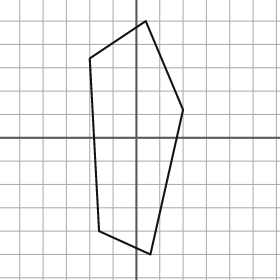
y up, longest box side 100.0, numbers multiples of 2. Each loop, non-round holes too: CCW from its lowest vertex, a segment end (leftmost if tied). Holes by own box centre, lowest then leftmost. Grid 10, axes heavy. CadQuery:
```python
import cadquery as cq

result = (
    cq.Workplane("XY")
    .moveTo(6.0, -50.0)
    .lineTo(20.0, 12.0)
    .lineTo(4.0, 50.0)
    .lineTo(-20.0, 34.0)
    .lineTo(-16.0, -40.0)
    .close()
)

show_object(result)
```